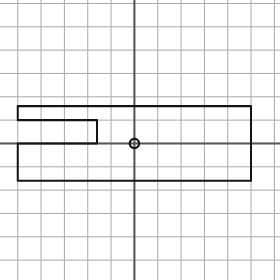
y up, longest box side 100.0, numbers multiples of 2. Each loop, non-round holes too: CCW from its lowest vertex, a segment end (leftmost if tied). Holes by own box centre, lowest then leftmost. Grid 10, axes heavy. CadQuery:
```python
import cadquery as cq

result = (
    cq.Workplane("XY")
    .moveTo(-50.0, -16.0)
    .lineTo(50.0, -16.0)
    .lineTo(50.0, 16.0)
    .lineTo(-50.0, 16.0)
    .lineTo(-50.0, 10.0)
    .lineTo(-16.0, 10.0)
    .lineTo(-16.0, 0.0)
    .lineTo(-50.0, 0.0)
    .close()
    .moveTo(0.0, 0.0)
    .circle(2.0)
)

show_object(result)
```